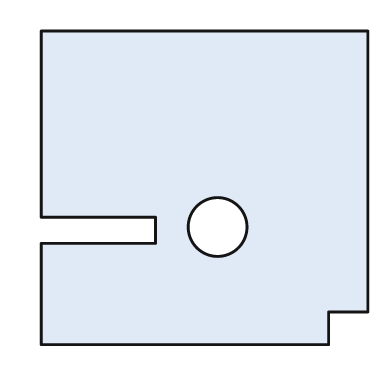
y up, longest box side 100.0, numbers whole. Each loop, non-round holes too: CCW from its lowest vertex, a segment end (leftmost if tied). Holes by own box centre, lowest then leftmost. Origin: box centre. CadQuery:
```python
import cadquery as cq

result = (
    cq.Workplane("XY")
    .moveTo(-50.0, -48.0)
    .lineTo(38.0, -48.0)
    .lineTo(38.0, -38.0)
    .lineTo(50.0, -38.0)
    .lineTo(50.0, 48.0)
    .lineTo(-50.0, 48.0)
    .lineTo(-50.0, -9.0)
    .lineTo(-15.0, -9.0)
    .lineTo(-15.0, -17.0)
    .lineTo(-50.0, -17.0)
    .close()
    .moveTo(4.0, -12.0)
    .circle(9.0)
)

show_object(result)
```